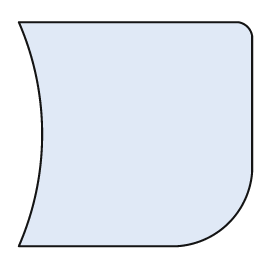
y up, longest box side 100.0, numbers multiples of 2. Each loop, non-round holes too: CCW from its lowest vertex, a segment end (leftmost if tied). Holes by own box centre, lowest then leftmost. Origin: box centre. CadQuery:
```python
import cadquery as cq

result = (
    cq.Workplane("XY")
    .moveTo(-50.0, -48.0)
    .lineTo(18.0, -48.0)
    .threePointArc((40.0, -38.0), (50.0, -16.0))
    .lineTo(50.0, 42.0)
    .threePointArc((48.0, 46.0), (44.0, 48.0))
    .lineTo(-50.0, 48.0)
    .threePointArc((-40.0, 0.0), (-50.0, -48.0))
    .close()
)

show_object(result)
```